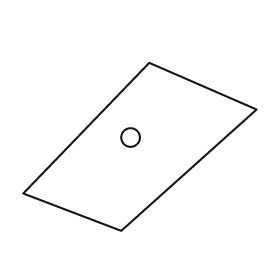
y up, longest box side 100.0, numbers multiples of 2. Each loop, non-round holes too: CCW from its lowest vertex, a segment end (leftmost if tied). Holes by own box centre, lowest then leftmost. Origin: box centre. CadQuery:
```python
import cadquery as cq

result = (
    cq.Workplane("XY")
    .moveTo(-8.0, -36.0)
    .lineTo(50.0, 16.0)
    .lineTo(4.0, 36.0)
    .lineTo(-50.0, -20.0)
    .close()
    .moveTo(-4.0, 4.0)
    .circle(4.0)
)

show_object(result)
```